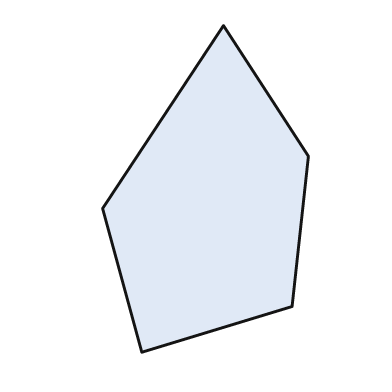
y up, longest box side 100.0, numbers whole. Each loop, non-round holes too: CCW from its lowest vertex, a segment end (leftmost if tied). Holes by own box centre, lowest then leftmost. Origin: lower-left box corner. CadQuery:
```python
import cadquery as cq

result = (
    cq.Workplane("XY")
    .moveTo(12.0, 0.0)
    .lineTo(58.0, 14.0)
    .lineTo(63.0, 60.0)
    .lineTo(37.0, 100.0)
    .lineTo(0.0, 44.0)
    .close()
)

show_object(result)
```